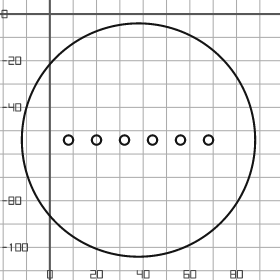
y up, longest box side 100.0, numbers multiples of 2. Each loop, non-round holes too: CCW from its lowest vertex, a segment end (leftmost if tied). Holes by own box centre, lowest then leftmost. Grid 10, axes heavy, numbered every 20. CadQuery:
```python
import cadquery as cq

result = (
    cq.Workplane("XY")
    .moveTo(38.0, -54.0)
    .circle(50.0)
    .moveTo(8.0, -54.0)
    .circle(2.0)
    .moveTo(20.0, -54.0)
    .circle(2.0)
    .moveTo(32.0, -54.0)
    .circle(2.0)
    .moveTo(44.0, -54.0)
    .circle(2.0)
    .moveTo(56.0, -54.0)
    .circle(2.0)
    .moveTo(68.0, -54.0)
    .circle(2.0)
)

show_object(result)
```